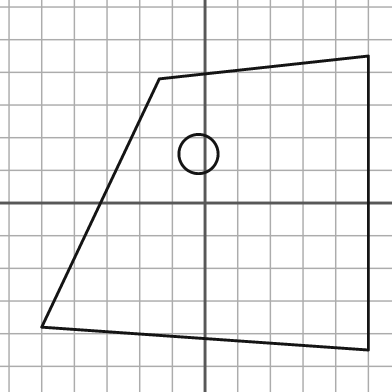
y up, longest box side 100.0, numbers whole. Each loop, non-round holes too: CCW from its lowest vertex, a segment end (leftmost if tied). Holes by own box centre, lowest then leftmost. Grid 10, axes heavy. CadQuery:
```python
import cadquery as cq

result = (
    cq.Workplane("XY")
    .moveTo(50.0, -45.0)
    .lineTo(50.0, 45.0)
    .lineTo(-14.0, 38.0)
    .lineTo(-50.0, -38.0)
    .close()
    .moveTo(-2.0, 15.0)
    .circle(6.0)
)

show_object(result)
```